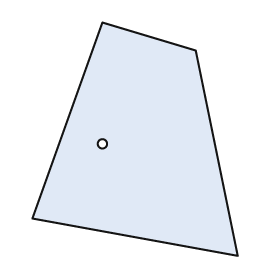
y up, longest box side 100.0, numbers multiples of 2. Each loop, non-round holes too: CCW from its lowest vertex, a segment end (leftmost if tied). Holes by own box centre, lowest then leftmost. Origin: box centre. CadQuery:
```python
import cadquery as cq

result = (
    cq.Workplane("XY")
    .moveTo(44.0, -50.0)
    .lineTo(26.0, 38.0)
    .lineTo(-14.0, 50.0)
    .lineTo(-44.0, -34.0)
    .close()
    .moveTo(-14.0, -2.0)
    .circle(2.0)
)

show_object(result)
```